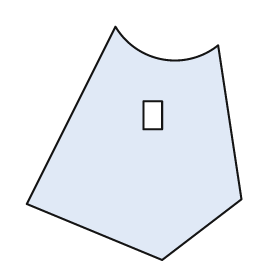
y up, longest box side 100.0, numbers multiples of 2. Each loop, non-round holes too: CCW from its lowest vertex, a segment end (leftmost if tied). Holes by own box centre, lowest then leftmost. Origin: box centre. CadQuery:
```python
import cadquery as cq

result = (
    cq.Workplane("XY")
    .moveTo(12.0, -50.0)
    .lineTo(46.0, -24.0)
    .lineTo(36.0, 42.0)
    .threePointArc((12.0, 36.0), (-8.0, 50.0))
    .lineTo(-46.0, -26.0)
    .close()
    .moveTo(4.0, 6.0)
    .lineTo(12.0, 6.0)
    .lineTo(12.0, 18.0)
    .lineTo(4.0, 18.0)
    .close()
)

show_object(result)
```